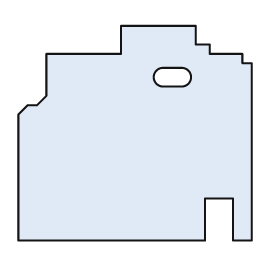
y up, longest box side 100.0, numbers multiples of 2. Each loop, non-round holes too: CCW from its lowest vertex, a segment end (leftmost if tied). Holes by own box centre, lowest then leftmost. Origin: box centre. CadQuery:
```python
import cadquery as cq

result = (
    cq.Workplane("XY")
    .moveTo(-50.0, -46.0)
    .lineTo(30.0, -46.0)
    .lineTo(30.0, -28.0)
    .lineTo(42.0, -28.0)
    .lineTo(42.0, -46.0)
    .lineTo(50.0, -46.0)
    .lineTo(50.0, 30.0)
    .lineTo(46.0, 30.0)
    .lineTo(46.0, 34.0)
    .lineTo(32.0, 34.0)
    .lineTo(32.0, 38.0)
    .lineTo(26.0, 38.0)
    .lineTo(26.0, 46.0)
    .lineTo(-6.0, 46.0)
    .lineTo(-6.0, 34.0)
    .lineTo(-38.0, 34.0)
    .lineTo(-38.0, 16.0)
    .lineTo(-42.0, 12.0)
    .lineTo(-46.0, 12.0)
    .lineTo(-50.0, 8.0)
    .close()
    .moveTo(12.0, 20.0)
    .lineTo(20.0, 20.0)
    .threePointArc((24.0, 24.0), (20.0, 28.0))
    .lineTo(12.0, 28.0)
    .threePointArc((8.0, 24.0), (12.0, 20.0))
    .close()
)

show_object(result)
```